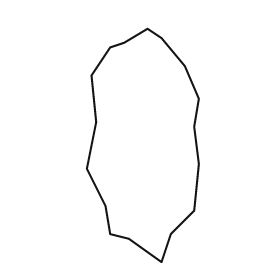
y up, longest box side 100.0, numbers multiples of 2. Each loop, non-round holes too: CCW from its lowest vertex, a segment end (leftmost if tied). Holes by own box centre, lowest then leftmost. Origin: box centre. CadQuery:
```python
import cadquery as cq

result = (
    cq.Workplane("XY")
    .moveTo(8.0, -50.0)
    .lineTo(12.0, -38.0)
    .lineTo(22.0, -28.0)
    .lineTo(24.0, -8.0)
    .lineTo(22.0, 8.0)
    .lineTo(24.0, 20.0)
    .lineTo(18.0, 34.0)
    .lineTo(8.0, 46.0)
    .lineTo(2.0, 50.0)
    .lineTo(-8.0, 44.0)
    .lineTo(-14.0, 42.0)
    .lineTo(-22.0, 30.0)
    .lineTo(-20.0, 10.0)
    .lineTo(-24.0, -10.0)
    .lineTo(-16.0, -26.0)
    .lineTo(-14.0, -38.0)
    .lineTo(-6.0, -40.0)
    .close()
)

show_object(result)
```